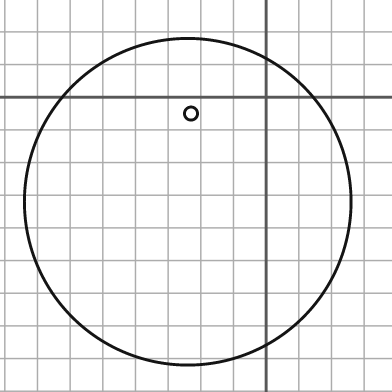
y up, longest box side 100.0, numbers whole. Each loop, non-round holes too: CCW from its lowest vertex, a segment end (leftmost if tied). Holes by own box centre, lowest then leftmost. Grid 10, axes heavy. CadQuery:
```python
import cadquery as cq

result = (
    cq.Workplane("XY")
    .moveTo(-24.0, -32.0)
    .circle(50.0)
    .moveTo(-23.0, -5.0)
    .circle(2.0)
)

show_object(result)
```